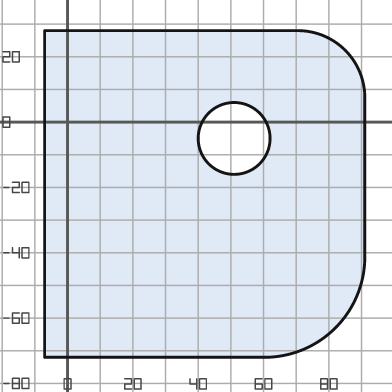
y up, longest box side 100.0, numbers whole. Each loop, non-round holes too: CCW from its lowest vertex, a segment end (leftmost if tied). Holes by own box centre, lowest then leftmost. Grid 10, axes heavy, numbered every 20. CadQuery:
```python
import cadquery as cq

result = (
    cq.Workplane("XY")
    .moveTo(-7.0, -72.0)
    .lineTo(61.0, -72.0)
    .threePointArc((82.0, -63.0), (91.0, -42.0))
    .lineTo(91.0, 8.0)
    .threePointArc((85.0, 22.0), (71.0, 28.0))
    .lineTo(-7.0, 28.0)
    .close()
    .moveTo(51.0, -5.0)
    .circle(11.0)
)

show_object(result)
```